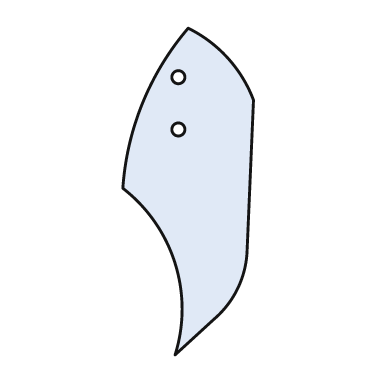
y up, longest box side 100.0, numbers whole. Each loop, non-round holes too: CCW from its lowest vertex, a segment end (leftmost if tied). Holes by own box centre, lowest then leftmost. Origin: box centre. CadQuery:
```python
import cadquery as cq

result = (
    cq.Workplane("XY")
    .moveTo(-4.0, -50.0)
    .lineTo(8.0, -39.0)
    .threePointArc((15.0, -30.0), (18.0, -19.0))
    .lineTo(20.0, 28.0)
    .threePointArc((12.0, 41.0), (0.0, 50.0))
    .threePointArc((-14.0, 27.0), (-20.0, 1.0))
    .threePointArc((-4.0, -22.0), (-4.0, -50.0))
    .close()
    .moveTo(-3.0, 19.0)
    .circle(2.0)
    .moveTo(-3.0, 35.0)
    .circle(2.0)
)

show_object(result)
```